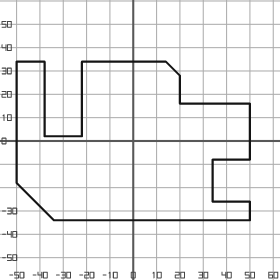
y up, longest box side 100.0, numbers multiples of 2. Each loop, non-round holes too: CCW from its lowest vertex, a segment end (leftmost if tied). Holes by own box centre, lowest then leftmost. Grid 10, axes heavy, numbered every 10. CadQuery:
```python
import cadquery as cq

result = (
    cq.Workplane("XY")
    .moveTo(-34.0, -34.0)
    .lineTo(50.0, -34.0)
    .lineTo(50.0, -26.0)
    .lineTo(34.0, -26.0)
    .lineTo(34.0, -8.0)
    .lineTo(50.0, -8.0)
    .lineTo(50.0, 16.0)
    .lineTo(20.0, 16.0)
    .lineTo(20.0, 28.0)
    .lineTo(14.0, 34.0)
    .lineTo(-22.0, 34.0)
    .lineTo(-22.0, 2.0)
    .lineTo(-38.0, 2.0)
    .lineTo(-38.0, 34.0)
    .lineTo(-50.0, 34.0)
    .lineTo(-50.0, -18.0)
    .close()
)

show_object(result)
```